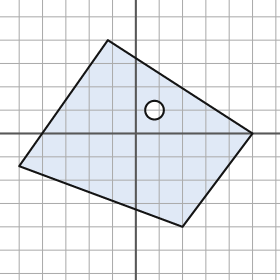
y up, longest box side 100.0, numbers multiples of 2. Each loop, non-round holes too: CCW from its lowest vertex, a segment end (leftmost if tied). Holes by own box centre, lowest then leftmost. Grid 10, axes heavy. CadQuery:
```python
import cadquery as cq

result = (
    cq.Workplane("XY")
    .moveTo(20.0, -40.0)
    .lineTo(50.0, 0.0)
    .lineTo(-12.0, 40.0)
    .lineTo(-50.0, -14.0)
    .close()
    .moveTo(8.0, 10.0)
    .circle(4.0)
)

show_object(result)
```